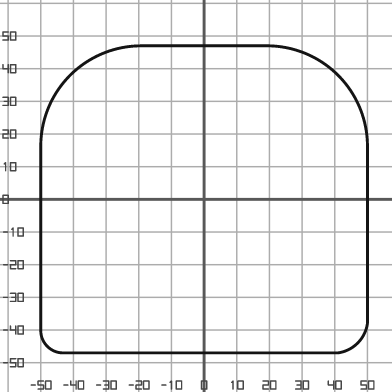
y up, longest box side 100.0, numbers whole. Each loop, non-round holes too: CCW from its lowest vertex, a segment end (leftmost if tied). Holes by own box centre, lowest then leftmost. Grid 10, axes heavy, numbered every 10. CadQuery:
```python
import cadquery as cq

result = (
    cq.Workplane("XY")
    .moveTo(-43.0, -47.0)
    .lineTo(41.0, -47.0)
    .threePointArc((47.0, -44.0), (50.0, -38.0))
    .lineTo(50.0, 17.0)
    .threePointArc((41.0, 38.0), (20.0, 47.0))
    .lineTo(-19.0, 47.0)
    .threePointArc((-41.0, 38.0), (-50.0, 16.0))
    .lineTo(-50.0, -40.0)
    .threePointArc((-48.0, -45.0), (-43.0, -47.0))
    .close()
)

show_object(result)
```